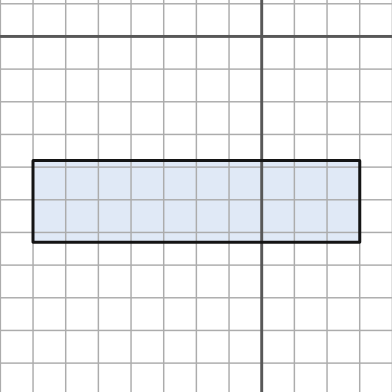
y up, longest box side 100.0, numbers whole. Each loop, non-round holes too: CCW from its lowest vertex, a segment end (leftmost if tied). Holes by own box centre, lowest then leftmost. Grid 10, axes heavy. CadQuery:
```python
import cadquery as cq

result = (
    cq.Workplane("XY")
    .moveTo(-70.0, -63.0)
    .lineTo(30.0, -63.0)
    .lineTo(30.0, -38.0)
    .lineTo(-70.0, -38.0)
    .close()
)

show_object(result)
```